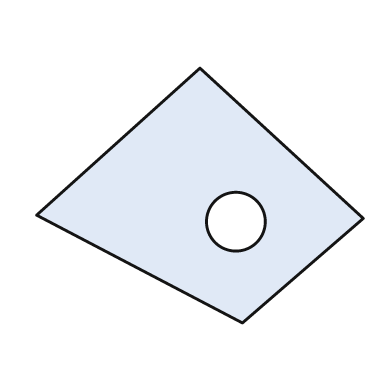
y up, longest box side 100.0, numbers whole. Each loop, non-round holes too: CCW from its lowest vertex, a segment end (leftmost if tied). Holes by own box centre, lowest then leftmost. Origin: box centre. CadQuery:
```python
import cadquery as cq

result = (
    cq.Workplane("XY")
    .moveTo(13.0, -39.0)
    .lineTo(50.0, -7.0)
    .lineTo(0.0, 39.0)
    .lineTo(-50.0, -6.0)
    .close()
    .moveTo(11.0, -8.0)
    .circle(9.0)
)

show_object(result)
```